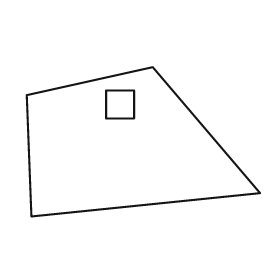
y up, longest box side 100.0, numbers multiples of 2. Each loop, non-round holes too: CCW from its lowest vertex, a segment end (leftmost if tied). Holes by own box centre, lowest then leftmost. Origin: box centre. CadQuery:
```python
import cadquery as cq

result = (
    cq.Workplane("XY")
    .moveTo(-48.0, -32.0)
    .lineTo(50.0, -22.0)
    .lineTo(4.0, 32.0)
    .lineTo(-50.0, 20.0)
    .close()
    .moveTo(-16.0, 10.0)
    .lineTo(-4.0, 10.0)
    .lineTo(-4.0, 22.0)
    .lineTo(-16.0, 22.0)
    .close()
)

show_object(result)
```